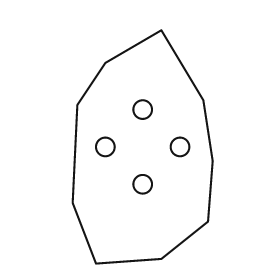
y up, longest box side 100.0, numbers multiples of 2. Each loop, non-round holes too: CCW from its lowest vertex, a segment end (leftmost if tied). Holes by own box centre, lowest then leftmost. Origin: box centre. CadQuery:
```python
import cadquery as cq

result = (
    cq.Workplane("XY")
    .moveTo(-20.0, -50.0)
    .lineTo(8.0, -48.0)
    .lineTo(28.0, -32.0)
    .lineTo(30.0, -6.0)
    .lineTo(26.0, 20.0)
    .lineTo(8.0, 50.0)
    .lineTo(-16.0, 36.0)
    .lineTo(-28.0, 18.0)
    .lineTo(-30.0, -24.0)
    .close()
    .moveTo(0.0, -16.0)
    .circle(4.0)
    .moveTo(-16.0, 0.0)
    .circle(4.0)
    .moveTo(16.0, 0.0)
    .circle(4.0)
    .moveTo(0.0, 16.0)
    .circle(4.0)
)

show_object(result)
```